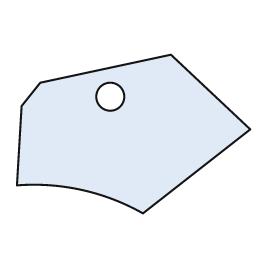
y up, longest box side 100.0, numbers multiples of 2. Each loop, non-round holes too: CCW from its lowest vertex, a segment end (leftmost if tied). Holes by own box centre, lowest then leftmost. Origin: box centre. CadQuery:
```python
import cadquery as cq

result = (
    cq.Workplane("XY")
    .moveTo(4.0, -34.0)
    .lineTo(50.0, 2.0)
    .lineTo(16.0, 34.0)
    .lineTo(-40.0, 22.0)
    .lineTo(-48.0, 12.0)
    .lineTo(-50.0, -22.0)
    .threePointArc((-22.0, -24.0), (4.0, -34.0))
    .close()
    .moveTo(-10.0, 16.0)
    .circle(6.0)
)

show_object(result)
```